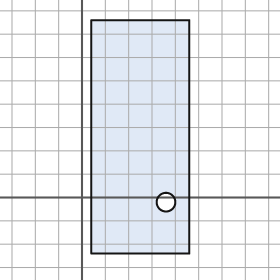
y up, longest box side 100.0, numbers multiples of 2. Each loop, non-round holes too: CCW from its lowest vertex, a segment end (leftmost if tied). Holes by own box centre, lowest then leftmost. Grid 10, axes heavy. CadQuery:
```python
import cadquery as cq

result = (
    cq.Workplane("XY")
    .moveTo(4.0, -24.0)
    .lineTo(46.0, -24.0)
    .lineTo(46.0, 76.0)
    .lineTo(4.0, 76.0)
    .close()
    .moveTo(36.0, -2.0)
    .circle(4.0)
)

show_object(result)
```